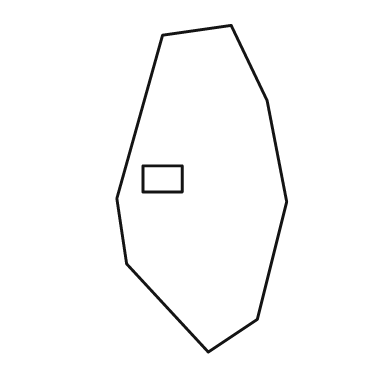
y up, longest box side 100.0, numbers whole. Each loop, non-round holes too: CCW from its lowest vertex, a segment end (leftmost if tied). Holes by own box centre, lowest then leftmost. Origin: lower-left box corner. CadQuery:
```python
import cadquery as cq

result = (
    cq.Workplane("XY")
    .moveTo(28.0, 0.0)
    .lineTo(43.0, 10.0)
    .lineTo(52.0, 46.0)
    .lineTo(46.0, 77.0)
    .lineTo(35.0, 100.0)
    .lineTo(14.0, 97.0)
    .lineTo(0.0, 47.0)
    .lineTo(3.0, 27.0)
    .close()
    .moveTo(8.0, 49.0)
    .lineTo(20.0, 49.0)
    .lineTo(20.0, 57.0)
    .lineTo(8.0, 57.0)
    .close()
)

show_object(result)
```